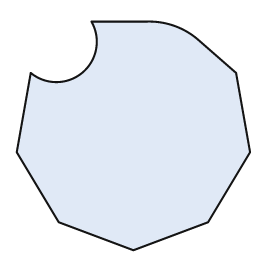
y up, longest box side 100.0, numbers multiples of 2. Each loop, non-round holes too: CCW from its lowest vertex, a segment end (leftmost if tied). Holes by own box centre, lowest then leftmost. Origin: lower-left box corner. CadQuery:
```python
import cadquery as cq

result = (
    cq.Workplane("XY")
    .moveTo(50.0, 0.0)
    .lineTo(82.0, 12.0)
    .lineTo(100.0, 42.0)
    .lineTo(94.0, 76.0)
    .lineTo(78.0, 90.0)
    .threePointArc((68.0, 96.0), (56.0, 98.0))
    .lineTo(32.0, 98.0)
    .threePointArc((28.0, 76.0), (6.0, 76.0))
    .lineTo(0.0, 42.0)
    .lineTo(18.0, 12.0)
    .close()
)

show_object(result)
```